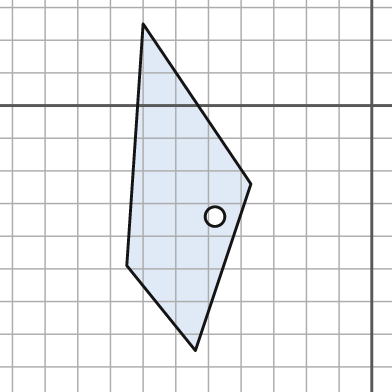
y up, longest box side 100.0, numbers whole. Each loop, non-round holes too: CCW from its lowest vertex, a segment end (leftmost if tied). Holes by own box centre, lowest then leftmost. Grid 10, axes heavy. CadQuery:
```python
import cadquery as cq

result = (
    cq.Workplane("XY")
    .moveTo(-54.0, -75.0)
    .lineTo(-37.0, -24.0)
    .lineTo(-70.0, 25.0)
    .lineTo(-75.0, -49.0)
    .close()
    .moveTo(-48.0, -34.0)
    .circle(3.0)
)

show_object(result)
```